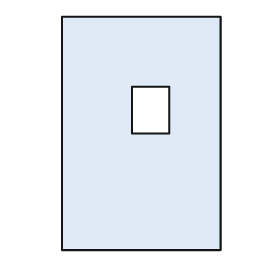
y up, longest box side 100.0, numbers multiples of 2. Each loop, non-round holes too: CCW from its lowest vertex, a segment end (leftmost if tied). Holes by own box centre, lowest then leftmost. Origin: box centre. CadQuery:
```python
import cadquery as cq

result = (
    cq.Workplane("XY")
    .moveTo(-34.0, -50.0)
    .lineTo(34.0, -50.0)
    .lineTo(34.0, 50.0)
    .lineTo(-34.0, 50.0)
    .close()
    .moveTo(-4.0, 0.0)
    .lineTo(12.0, 0.0)
    .lineTo(12.0, 20.0)
    .lineTo(-4.0, 20.0)
    .close()
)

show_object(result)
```